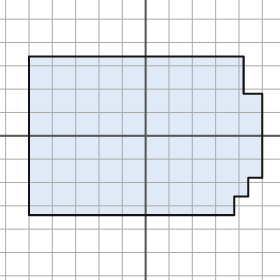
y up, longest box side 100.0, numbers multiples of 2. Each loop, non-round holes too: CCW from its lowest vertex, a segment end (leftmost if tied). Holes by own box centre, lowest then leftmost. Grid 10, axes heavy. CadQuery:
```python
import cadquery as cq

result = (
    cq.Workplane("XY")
    .moveTo(-50.0, -34.0)
    .lineTo(38.0, -34.0)
    .lineTo(38.0, -26.0)
    .lineTo(44.0, -26.0)
    .lineTo(44.0, -18.0)
    .lineTo(50.0, -18.0)
    .lineTo(50.0, 18.0)
    .lineTo(42.0, 18.0)
    .lineTo(42.0, 34.0)
    .lineTo(-50.0, 34.0)
    .close()
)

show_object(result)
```